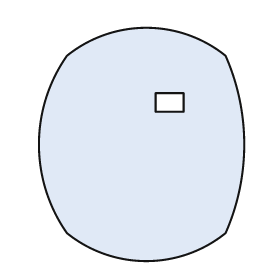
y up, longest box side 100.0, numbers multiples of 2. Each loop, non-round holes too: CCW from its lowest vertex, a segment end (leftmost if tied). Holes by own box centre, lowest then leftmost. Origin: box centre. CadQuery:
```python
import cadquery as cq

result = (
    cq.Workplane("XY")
    .moveTo(-32.0, -38.0)
    .threePointArc((2.0, -50.0), (36.0, -38.0))
    .threePointArc((44.0, 0.0), (36.0, 38.0))
    .threePointArc((2.0, 50.0), (-32.0, 38.0))
    .threePointArc((-44.0, 0.0), (-32.0, -38.0))
    .close()
    .moveTo(6.0, 14.0)
    .lineTo(18.0, 14.0)
    .lineTo(18.0, 22.0)
    .lineTo(6.0, 22.0)
    .close()
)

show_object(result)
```